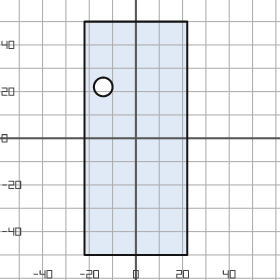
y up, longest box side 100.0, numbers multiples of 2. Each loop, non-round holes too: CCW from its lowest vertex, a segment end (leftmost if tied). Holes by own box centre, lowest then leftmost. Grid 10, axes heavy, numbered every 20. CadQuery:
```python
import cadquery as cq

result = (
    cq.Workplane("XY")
    .moveTo(-22.0, -50.0)
    .lineTo(22.0, -50.0)
    .lineTo(22.0, 50.0)
    .lineTo(-22.0, 50.0)
    .close()
    .moveTo(-14.0, 22.0)
    .circle(4.0)
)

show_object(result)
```